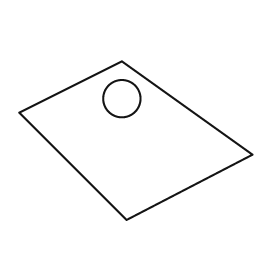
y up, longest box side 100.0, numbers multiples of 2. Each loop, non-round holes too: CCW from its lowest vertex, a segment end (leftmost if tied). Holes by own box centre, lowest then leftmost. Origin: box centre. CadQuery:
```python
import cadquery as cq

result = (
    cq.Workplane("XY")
    .moveTo(-4.0, -34.0)
    .lineTo(50.0, -6.0)
    .lineTo(-6.0, 34.0)
    .lineTo(-50.0, 12.0)
    .close()
    .moveTo(-6.0, 18.0)
    .circle(8.0)
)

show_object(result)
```